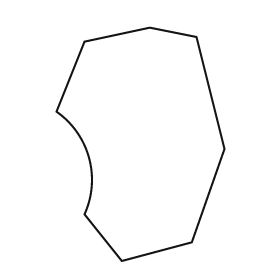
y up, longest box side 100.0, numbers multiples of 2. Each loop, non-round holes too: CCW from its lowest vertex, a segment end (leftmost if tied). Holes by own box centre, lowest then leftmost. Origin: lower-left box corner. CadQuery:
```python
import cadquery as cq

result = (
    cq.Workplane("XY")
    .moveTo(28.0, 0.0)
    .lineTo(58.0, 8.0)
    .lineTo(72.0, 48.0)
    .lineTo(60.0, 96.0)
    .lineTo(40.0, 100.0)
    .lineTo(12.0, 94.0)
    .lineTo(0.0, 64.0)
    .threePointArc((14.0, 44.0), (12.0, 20.0))
    .close()
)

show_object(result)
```